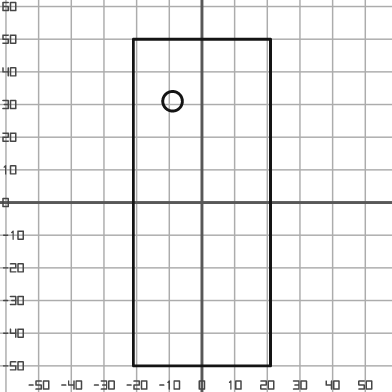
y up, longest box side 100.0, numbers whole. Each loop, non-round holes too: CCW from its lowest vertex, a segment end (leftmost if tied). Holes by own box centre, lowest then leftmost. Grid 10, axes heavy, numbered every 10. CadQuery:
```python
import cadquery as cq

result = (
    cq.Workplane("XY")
    .moveTo(-21.0, -50.0)
    .lineTo(21.0, -50.0)
    .lineTo(21.0, 50.0)
    .lineTo(-21.0, 50.0)
    .close()
    .moveTo(-9.0, 31.0)
    .circle(3.0)
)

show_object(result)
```